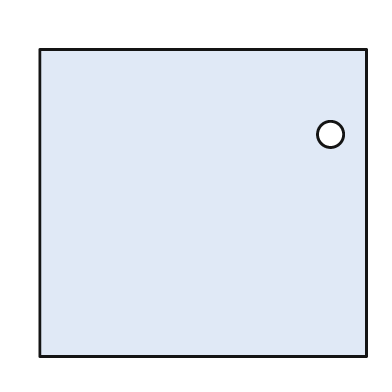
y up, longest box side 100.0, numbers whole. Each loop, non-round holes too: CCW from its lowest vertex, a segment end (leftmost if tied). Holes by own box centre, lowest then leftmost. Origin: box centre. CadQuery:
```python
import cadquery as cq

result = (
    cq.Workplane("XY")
    .moveTo(-50.0, -47.0)
    .lineTo(50.0, -47.0)
    .lineTo(50.0, 47.0)
    .lineTo(-50.0, 47.0)
    .close()
    .moveTo(39.0, 21.0)
    .circle(4.0)
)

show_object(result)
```